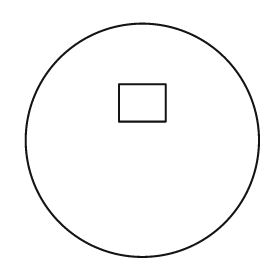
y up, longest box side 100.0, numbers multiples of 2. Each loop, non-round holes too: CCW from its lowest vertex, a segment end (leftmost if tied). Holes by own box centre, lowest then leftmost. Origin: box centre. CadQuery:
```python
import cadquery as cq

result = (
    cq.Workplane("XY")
    .moveTo(0.0, 0.0)
    .circle(50.0)
    .moveTo(-10.0, 8.0)
    .lineTo(10.0, 8.0)
    .lineTo(10.0, 24.0)
    .lineTo(-10.0, 24.0)
    .close()
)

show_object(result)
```